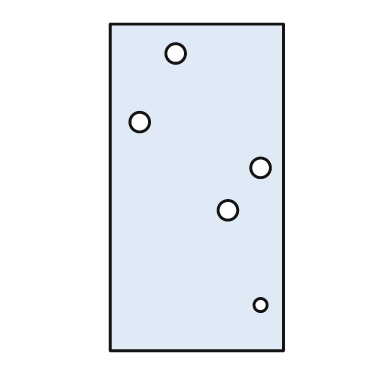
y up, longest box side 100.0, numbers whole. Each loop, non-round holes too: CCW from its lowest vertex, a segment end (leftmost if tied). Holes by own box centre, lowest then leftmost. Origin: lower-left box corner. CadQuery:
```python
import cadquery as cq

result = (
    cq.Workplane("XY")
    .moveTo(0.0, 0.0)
    .lineTo(53.0, 0.0)
    .lineTo(53.0, 100.0)
    .lineTo(0.0, 100.0)
    .close()
    .moveTo(46.0, 14.0)
    .circle(2.0)
    .moveTo(36.0, 43.0)
    .circle(3.0)
    .moveTo(46.0, 56.0)
    .circle(3.0)
    .moveTo(9.0, 70.0)
    .circle(3.0)
    .moveTo(20.0, 91.0)
    .circle(3.0)
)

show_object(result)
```